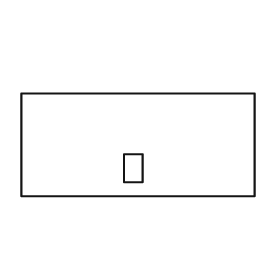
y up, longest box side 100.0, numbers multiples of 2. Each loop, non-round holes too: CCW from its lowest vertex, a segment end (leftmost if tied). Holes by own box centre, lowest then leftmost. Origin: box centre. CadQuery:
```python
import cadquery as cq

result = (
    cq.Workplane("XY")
    .moveTo(-50.0, -22.0)
    .lineTo(50.0, -22.0)
    .lineTo(50.0, 22.0)
    .lineTo(-50.0, 22.0)
    .close()
    .moveTo(-6.0, -16.0)
    .lineTo(2.0, -16.0)
    .lineTo(2.0, -4.0)
    .lineTo(-6.0, -4.0)
    .close()
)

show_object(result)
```